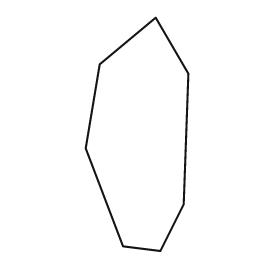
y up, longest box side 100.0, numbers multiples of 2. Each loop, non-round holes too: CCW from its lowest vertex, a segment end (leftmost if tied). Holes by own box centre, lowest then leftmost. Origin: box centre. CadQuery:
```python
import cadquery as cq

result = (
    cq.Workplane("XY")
    .moveTo(10.0, -50.0)
    .lineTo(20.0, -30.0)
    .lineTo(22.0, 26.0)
    .lineTo(8.0, 50.0)
    .lineTo(-16.0, 30.0)
    .lineTo(-22.0, -6.0)
    .lineTo(-6.0, -48.0)
    .close()
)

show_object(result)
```